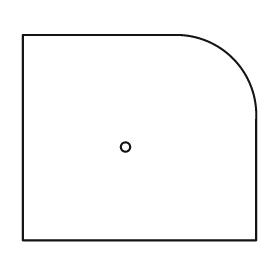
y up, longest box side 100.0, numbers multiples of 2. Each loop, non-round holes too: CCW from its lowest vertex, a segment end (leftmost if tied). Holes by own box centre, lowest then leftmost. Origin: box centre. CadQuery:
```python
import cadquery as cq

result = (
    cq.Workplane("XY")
    .moveTo(-50.0, -44.0)
    .lineTo(50.0, -44.0)
    .lineTo(50.0, 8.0)
    .threePointArc((40.0, 34.0), (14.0, 44.0))
    .lineTo(-50.0, 44.0)
    .close()
    .moveTo(-6.0, -4.0)
    .circle(2.0)
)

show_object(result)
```